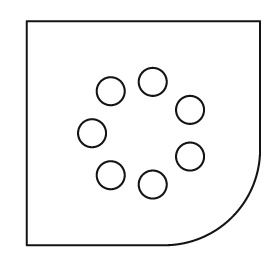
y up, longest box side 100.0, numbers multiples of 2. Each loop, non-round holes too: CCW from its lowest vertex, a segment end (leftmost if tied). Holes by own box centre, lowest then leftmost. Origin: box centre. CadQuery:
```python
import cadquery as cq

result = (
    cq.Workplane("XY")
    .moveTo(-50.0, -48.0)
    .lineTo(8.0, -48.0)
    .threePointArc((38.0, -36.0), (50.0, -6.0))
    .lineTo(50.0, 48.0)
    .lineTo(-50.0, 48.0)
    .close()
    .moveTo(4.0, -22.0)
    .circle(6.0)
    .moveTo(-14.0, -18.0)
    .circle(6.0)
    .moveTo(20.0, -10.0)
    .circle(6.0)
    .moveTo(-22.0, 0.0)
    .circle(6.0)
    .moveTo(20.0, 10.0)
    .circle(6.0)
    .moveTo(-14.0, 18.0)
    .circle(6.0)
    .moveTo(4.0, 22.0)
    .circle(6.0)
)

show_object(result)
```